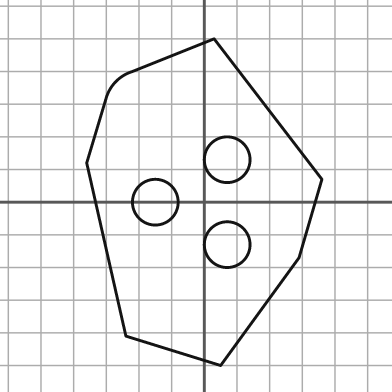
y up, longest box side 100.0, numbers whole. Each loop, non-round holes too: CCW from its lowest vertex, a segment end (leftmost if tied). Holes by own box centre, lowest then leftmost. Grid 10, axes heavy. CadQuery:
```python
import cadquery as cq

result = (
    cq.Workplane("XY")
    .moveTo(5.0, -50.0)
    .lineTo(29.0, -17.0)
    .lineTo(36.0, 7.0)
    .lineTo(3.0, 50.0)
    .lineTo(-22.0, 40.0)
    .threePointArc((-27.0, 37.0), (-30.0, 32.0))
    .lineTo(-36.0, 12.0)
    .lineTo(-24.0, -41.0)
    .close()
    .moveTo(7.0, -13.0)
    .circle(7.0)
    .moveTo(-15.0, 0.0)
    .circle(7.0)
    .moveTo(7.0, 13.0)
    .circle(7.0)
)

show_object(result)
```